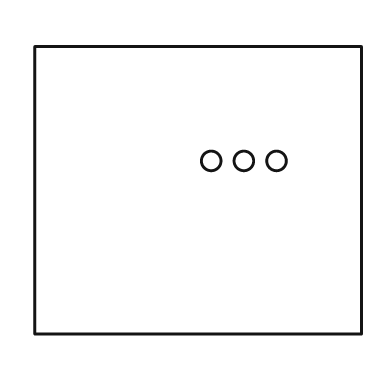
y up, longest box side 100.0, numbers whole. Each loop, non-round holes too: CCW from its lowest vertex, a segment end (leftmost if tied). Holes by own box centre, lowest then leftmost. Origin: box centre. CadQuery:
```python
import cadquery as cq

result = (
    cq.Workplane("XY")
    .moveTo(-50.0, -44.0)
    .lineTo(50.0, -44.0)
    .lineTo(50.0, 44.0)
    .lineTo(-50.0, 44.0)
    .close()
    .moveTo(4.0, 9.0)
    .circle(3.0)
    .moveTo(14.0, 9.0)
    .circle(3.0)
    .moveTo(24.0, 9.0)
    .circle(3.0)
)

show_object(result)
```